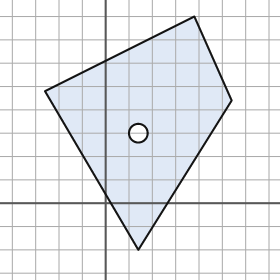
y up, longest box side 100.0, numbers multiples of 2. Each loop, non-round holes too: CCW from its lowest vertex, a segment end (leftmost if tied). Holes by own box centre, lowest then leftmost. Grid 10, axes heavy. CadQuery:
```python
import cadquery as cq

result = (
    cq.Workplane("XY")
    .moveTo(14.0, -20.0)
    .lineTo(54.0, 44.0)
    .lineTo(38.0, 80.0)
    .lineTo(-26.0, 48.0)
    .close()
    .moveTo(14.0, 30.0)
    .circle(4.0)
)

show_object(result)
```